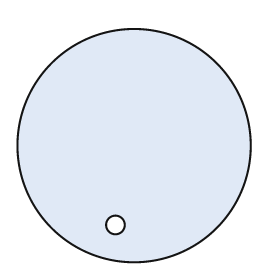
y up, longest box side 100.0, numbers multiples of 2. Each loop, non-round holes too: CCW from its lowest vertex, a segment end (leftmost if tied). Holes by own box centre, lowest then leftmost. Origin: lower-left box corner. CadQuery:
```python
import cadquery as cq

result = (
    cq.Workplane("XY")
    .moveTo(50.0, 50.0)
    .circle(50.0)
    .moveTo(42.0, 16.0)
    .circle(4.0)
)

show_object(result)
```